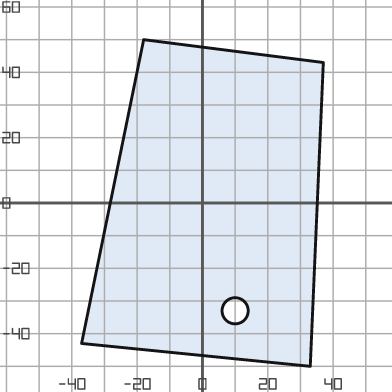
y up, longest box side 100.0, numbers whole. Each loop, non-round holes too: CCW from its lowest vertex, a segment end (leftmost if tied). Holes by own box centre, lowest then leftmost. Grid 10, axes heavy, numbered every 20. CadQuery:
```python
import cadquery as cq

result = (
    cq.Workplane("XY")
    .moveTo(33.0, -50.0)
    .lineTo(37.0, 43.0)
    .lineTo(-18.0, 50.0)
    .lineTo(-37.0, -43.0)
    .close()
    .moveTo(10.0, -33.0)
    .circle(4.0)
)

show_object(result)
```